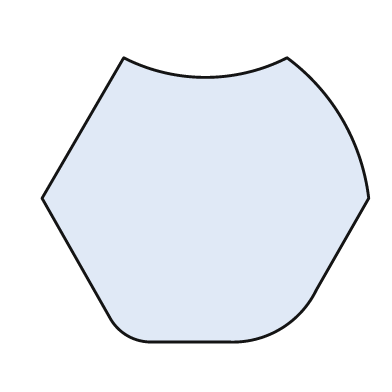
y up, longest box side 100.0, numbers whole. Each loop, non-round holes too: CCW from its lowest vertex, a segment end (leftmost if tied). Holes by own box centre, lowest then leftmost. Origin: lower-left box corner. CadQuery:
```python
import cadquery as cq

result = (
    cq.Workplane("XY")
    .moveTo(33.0, 0.0)
    .lineTo(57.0, 0.0)
    .threePointArc((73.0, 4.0), (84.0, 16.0))
    .lineTo(100.0, 44.0)
    .threePointArc((92.0, 68.0), (75.0, 87.0))
    .threePointArc((50.0, 81.0), (25.0, 87.0))
    .lineTo(0.0, 44.0)
    .lineTo(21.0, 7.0)
    .threePointArc((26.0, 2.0), (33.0, 0.0))
    .close()
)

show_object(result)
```